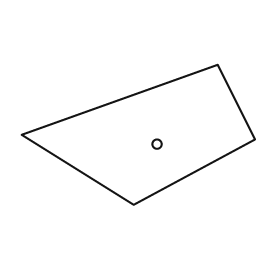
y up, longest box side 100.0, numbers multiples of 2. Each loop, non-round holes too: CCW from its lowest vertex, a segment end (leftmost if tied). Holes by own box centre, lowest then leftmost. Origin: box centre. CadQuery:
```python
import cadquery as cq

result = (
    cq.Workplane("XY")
    .moveTo(-2.0, -30.0)
    .lineTo(50.0, -2.0)
    .lineTo(34.0, 30.0)
    .lineTo(-50.0, 0.0)
    .close()
    .moveTo(8.0, -4.0)
    .circle(2.0)
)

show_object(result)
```